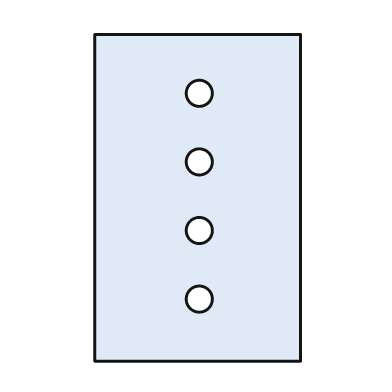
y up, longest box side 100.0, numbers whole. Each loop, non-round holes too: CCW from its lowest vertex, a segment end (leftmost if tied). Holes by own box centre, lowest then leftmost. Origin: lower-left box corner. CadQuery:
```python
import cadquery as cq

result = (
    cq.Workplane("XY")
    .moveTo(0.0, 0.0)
    .lineTo(63.0, 0.0)
    .lineTo(63.0, 100.0)
    .lineTo(0.0, 100.0)
    .close()
    .moveTo(32.0, 19.0)
    .circle(4.0)
    .moveTo(32.0, 40.0)
    .circle(4.0)
    .moveTo(32.0, 61.0)
    .circle(4.0)
    .moveTo(32.0, 82.0)
    .circle(4.0)
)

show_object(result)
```